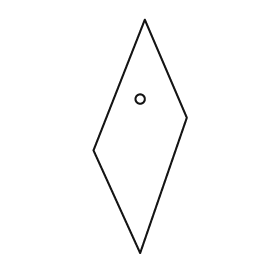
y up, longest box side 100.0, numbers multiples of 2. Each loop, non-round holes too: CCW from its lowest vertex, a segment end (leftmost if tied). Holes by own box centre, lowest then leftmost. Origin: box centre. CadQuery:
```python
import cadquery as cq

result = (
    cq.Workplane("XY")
    .moveTo(0.0, -50.0)
    .lineTo(20.0, 8.0)
    .lineTo(2.0, 50.0)
    .lineTo(-20.0, -6.0)
    .close()
    .moveTo(0.0, 16.0)
    .circle(2.0)
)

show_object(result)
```